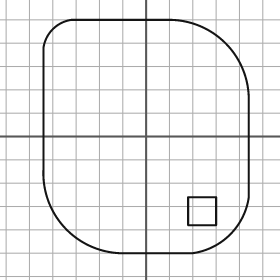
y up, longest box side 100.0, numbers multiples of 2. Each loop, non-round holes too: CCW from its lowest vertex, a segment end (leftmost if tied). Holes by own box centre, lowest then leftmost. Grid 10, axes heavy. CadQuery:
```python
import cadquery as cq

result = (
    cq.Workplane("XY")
    .moveTo(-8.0, -50.0)
    .lineTo(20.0, -50.0)
    .threePointArc((36.0, -42.0), (44.0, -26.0))
    .lineTo(44.0, 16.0)
    .threePointArc((34.0, 40.0), (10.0, 50.0))
    .lineTo(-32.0, 50.0)
    .threePointArc((-40.0, 46.0), (-44.0, 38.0))
    .lineTo(-44.0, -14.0)
    .threePointArc((-34.0, -40.0), (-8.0, -50.0))
    .close()
    .moveTo(18.0, -38.0)
    .lineTo(30.0, -38.0)
    .lineTo(30.0, -26.0)
    .lineTo(18.0, -26.0)
    .close()
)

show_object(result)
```